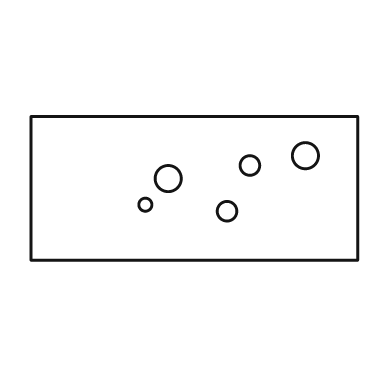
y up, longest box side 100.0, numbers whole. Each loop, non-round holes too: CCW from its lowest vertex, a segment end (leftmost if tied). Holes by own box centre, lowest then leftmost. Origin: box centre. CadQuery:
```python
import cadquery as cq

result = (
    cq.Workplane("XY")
    .moveTo(-50.0, -22.0)
    .lineTo(50.0, -22.0)
    .lineTo(50.0, 22.0)
    .lineTo(-50.0, 22.0)
    .close()
    .moveTo(10.0, -7.0)
    .circle(3.0)
    .moveTo(-15.0, -5.0)
    .circle(2.0)
    .moveTo(-8.0, 3.0)
    .circle(4.0)
    .moveTo(17.0, 7.0)
    .circle(3.0)
    .moveTo(34.0, 10.0)
    .circle(4.0)
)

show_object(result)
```